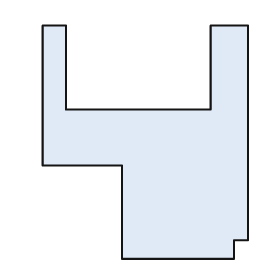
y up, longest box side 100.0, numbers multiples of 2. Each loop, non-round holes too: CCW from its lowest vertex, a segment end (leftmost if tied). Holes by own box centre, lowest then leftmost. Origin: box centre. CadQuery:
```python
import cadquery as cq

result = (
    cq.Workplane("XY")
    .moveTo(-10.0, -50.0)
    .lineTo(38.0, -50.0)
    .lineTo(38.0, -42.0)
    .lineTo(44.0, -42.0)
    .lineTo(44.0, 50.0)
    .lineTo(28.0, 50.0)
    .lineTo(28.0, 14.0)
    .lineTo(-34.0, 14.0)
    .lineTo(-34.0, 50.0)
    .lineTo(-44.0, 50.0)
    .lineTo(-44.0, -10.0)
    .lineTo(-10.0, -10.0)
    .close()
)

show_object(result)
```